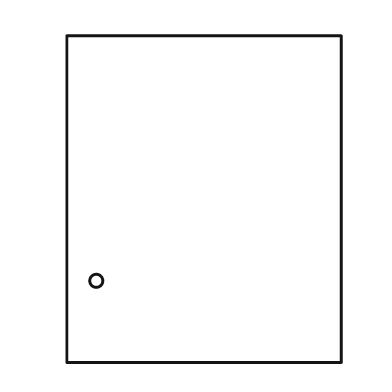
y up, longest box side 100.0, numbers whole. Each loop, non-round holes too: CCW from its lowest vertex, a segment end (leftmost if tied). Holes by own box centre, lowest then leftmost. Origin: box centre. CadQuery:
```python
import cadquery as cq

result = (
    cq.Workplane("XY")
    .moveTo(-42.0, -50.0)
    .lineTo(42.0, -50.0)
    .lineTo(42.0, 50.0)
    .lineTo(-42.0, 50.0)
    .close()
    .moveTo(-33.0, -25.0)
    .circle(2.0)
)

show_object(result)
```